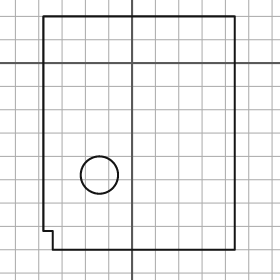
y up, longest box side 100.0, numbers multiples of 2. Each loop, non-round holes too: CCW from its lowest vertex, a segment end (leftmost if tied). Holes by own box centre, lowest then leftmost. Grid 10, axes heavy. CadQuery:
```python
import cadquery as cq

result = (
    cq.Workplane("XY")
    .moveTo(-34.0, -80.0)
    .lineTo(44.0, -80.0)
    .lineTo(44.0, 20.0)
    .lineTo(-38.0, 20.0)
    .lineTo(-38.0, -72.0)
    .lineTo(-34.0, -72.0)
    .close()
    .moveTo(-14.0, -48.0)
    .circle(8.0)
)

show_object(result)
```